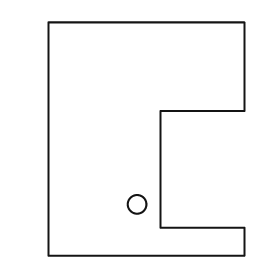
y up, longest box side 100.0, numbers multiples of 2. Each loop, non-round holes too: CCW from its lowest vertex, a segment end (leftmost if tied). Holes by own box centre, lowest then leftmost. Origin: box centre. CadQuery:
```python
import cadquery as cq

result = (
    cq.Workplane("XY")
    .moveTo(-42.0, -50.0)
    .lineTo(42.0, -50.0)
    .lineTo(42.0, -38.0)
    .lineTo(6.0, -38.0)
    .lineTo(6.0, 12.0)
    .lineTo(42.0, 12.0)
    .lineTo(42.0, 50.0)
    .lineTo(-42.0, 50.0)
    .close()
    .moveTo(-4.0, -28.0)
    .circle(4.0)
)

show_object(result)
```